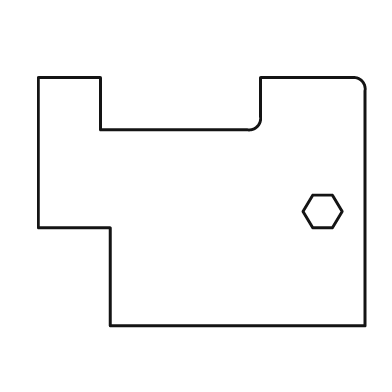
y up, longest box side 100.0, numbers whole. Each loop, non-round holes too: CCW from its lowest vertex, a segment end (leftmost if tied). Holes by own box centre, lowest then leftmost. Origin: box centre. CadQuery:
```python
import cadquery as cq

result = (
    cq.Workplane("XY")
    .moveTo(-28.0, -38.0)
    .lineTo(50.0, -38.0)
    .lineTo(50.0, 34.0)
    .threePointArc((49.0, 37.0), (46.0, 38.0))
    .lineTo(18.0, 38.0)
    .lineTo(18.0, 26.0)
    .threePointArc((17.0, 23.0), (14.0, 22.0))
    .lineTo(-31.0, 22.0)
    .lineTo(-31.0, 38.0)
    .lineTo(-50.0, 38.0)
    .lineTo(-50.0, -8.0)
    .lineTo(-28.0, -8.0)
    .close()
    .moveTo(34.0, -8.0)
    .lineTo(40.0, -8.0)
    .lineTo(43.0, -3.0)
    .lineTo(40.0, 2.0)
    .lineTo(34.0, 2.0)
    .lineTo(31.0, -3.0)
    .close()
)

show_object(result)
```